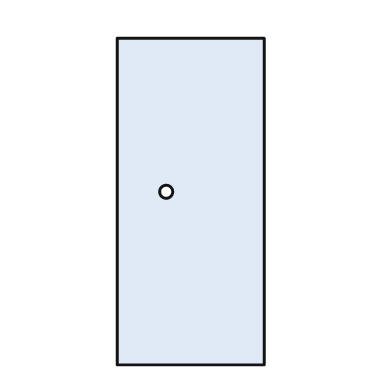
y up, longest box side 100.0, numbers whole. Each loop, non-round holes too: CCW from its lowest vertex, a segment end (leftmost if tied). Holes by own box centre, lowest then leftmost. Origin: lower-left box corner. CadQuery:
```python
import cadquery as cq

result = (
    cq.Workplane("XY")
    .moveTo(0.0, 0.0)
    .lineTo(45.0, 0.0)
    .lineTo(45.0, 100.0)
    .lineTo(0.0, 100.0)
    .close()
    .moveTo(15.0, 53.0)
    .circle(2.0)
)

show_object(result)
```